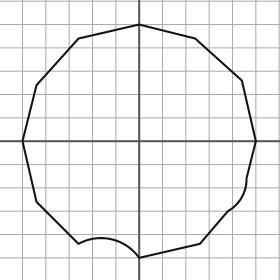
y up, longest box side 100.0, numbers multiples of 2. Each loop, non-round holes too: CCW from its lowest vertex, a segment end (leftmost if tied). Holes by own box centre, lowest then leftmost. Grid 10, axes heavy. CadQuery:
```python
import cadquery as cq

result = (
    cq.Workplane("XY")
    .moveTo(0.0, -50.0)
    .lineTo(26.0, -44.0)
    .lineTo(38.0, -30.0)
    .threePointArc((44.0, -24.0), (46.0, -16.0))
    .lineTo(50.0, 0.0)
    .lineTo(44.0, 26.0)
    .lineTo(24.0, 44.0)
    .lineTo(0.0, 50.0)
    .lineTo(-26.0, 44.0)
    .lineTo(-44.0, 24.0)
    .lineTo(-50.0, 0.0)
    .lineTo(-44.0, -26.0)
    .lineTo(-26.0, -44.0)
    .threePointArc((-12.0, -42.0), (0.0, -50.0))
    .close()
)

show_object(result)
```